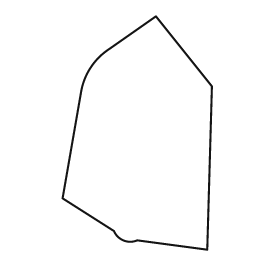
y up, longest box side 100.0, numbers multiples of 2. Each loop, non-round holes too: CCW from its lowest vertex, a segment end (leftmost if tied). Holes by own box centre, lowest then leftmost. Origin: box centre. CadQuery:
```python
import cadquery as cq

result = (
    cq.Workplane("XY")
    .moveTo(30.0, -50.0)
    .lineTo(32.0, 20.0)
    .lineTo(8.0, 50.0)
    .lineTo(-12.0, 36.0)
    .threePointArc((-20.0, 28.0), (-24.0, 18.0))
    .lineTo(-32.0, -28.0)
    .lineTo(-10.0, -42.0)
    .threePointArc((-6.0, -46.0), (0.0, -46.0))
    .close()
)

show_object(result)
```